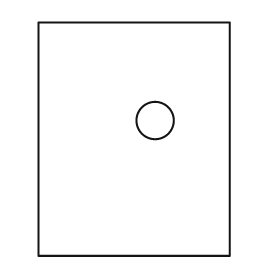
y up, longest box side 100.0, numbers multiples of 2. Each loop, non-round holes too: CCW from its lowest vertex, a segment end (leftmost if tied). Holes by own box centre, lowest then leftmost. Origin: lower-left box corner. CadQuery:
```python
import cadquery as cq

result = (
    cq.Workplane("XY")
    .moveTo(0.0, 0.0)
    .lineTo(82.0, 0.0)
    .lineTo(82.0, 100.0)
    .lineTo(0.0, 100.0)
    .close()
    .moveTo(50.0, 58.0)
    .circle(8.0)
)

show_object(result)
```